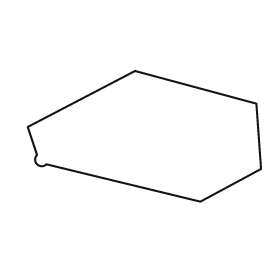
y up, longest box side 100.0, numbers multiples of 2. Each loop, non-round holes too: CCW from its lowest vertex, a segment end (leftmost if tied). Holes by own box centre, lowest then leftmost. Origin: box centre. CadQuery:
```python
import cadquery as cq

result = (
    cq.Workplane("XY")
    .moveTo(24.0, -28.0)
    .lineTo(50.0, -14.0)
    .lineTo(48.0, 14.0)
    .lineTo(-4.0, 28.0)
    .lineTo(-50.0, 4.0)
    .lineTo(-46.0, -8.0)
    .threePointArc((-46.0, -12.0), (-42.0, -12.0))
    .close()
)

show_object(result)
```